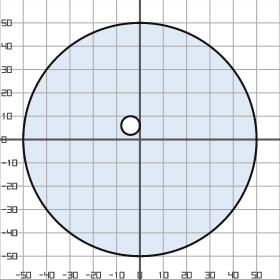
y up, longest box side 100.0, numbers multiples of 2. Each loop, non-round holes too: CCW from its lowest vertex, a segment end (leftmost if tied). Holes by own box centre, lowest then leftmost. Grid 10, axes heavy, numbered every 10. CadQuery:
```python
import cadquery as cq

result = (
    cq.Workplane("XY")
    .moveTo(0.0, 0.0)
    .circle(50.0)
    .moveTo(-4.0, 6.0)
    .circle(4.0)
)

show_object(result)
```